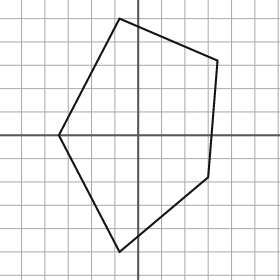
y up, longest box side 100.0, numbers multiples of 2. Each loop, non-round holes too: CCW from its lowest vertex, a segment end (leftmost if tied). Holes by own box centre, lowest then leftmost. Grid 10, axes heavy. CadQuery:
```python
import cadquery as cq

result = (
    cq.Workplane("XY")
    .moveTo(-8.0, -50.0)
    .lineTo(30.0, -18.0)
    .lineTo(34.0, 32.0)
    .lineTo(-8.0, 50.0)
    .lineTo(-34.0, 0.0)
    .close()
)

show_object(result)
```